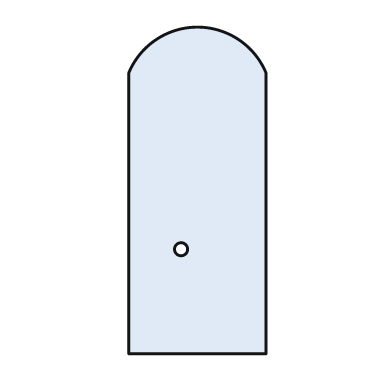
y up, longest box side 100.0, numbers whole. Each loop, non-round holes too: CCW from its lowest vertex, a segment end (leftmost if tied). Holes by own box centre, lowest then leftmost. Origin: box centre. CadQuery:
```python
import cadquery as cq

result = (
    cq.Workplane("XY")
    .moveTo(-21.0, -50.0)
    .lineTo(21.0, -50.0)
    .lineTo(21.0, 36.0)
    .threePointArc((0.0, 50.0), (-21.0, 36.0))
    .close()
    .moveTo(-5.0, -18.0)
    .circle(2.0)
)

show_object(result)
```